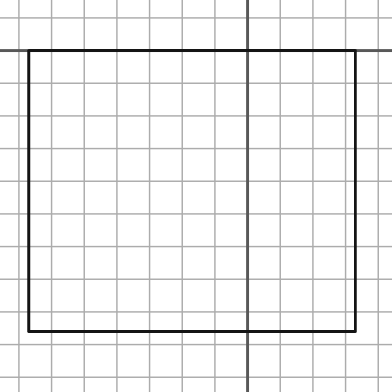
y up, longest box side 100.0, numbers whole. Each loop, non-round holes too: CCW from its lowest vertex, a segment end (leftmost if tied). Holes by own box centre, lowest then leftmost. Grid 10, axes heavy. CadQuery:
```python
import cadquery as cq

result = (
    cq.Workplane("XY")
    .moveTo(-67.0, -86.0)
    .lineTo(33.0, -86.0)
    .lineTo(33.0, 0.0)
    .lineTo(-67.0, 0.0)
    .close()
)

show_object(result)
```